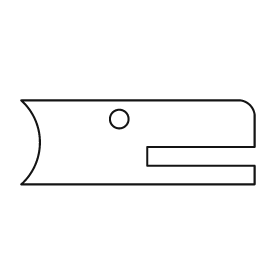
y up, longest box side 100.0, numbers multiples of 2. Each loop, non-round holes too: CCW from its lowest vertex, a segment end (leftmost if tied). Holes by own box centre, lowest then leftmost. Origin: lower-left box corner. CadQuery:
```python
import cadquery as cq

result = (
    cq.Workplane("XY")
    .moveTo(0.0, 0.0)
    .lineTo(100.0, 0.0)
    .lineTo(100.0, 8.0)
    .lineTo(54.0, 8.0)
    .lineTo(54.0, 16.0)
    .lineTo(100.0, 16.0)
    .lineTo(100.0, 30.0)
    .threePointArc((98.0, 34.0), (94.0, 36.0))
    .lineTo(0.0, 36.0)
    .threePointArc((8.0, 18.0), (0.0, 0.0))
    .close()
    .moveTo(42.0, 28.0)
    .circle(4.0)
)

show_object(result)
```